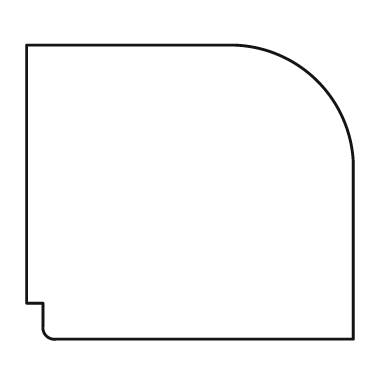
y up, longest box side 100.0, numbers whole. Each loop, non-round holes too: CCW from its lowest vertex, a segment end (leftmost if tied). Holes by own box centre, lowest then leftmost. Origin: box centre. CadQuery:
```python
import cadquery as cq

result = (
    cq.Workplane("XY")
    .moveTo(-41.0, -45.0)
    .lineTo(50.0, -45.0)
    .lineTo(50.0, 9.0)
    .threePointArc((39.0, 34.0), (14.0, 45.0))
    .lineTo(-50.0, 45.0)
    .lineTo(-50.0, -34.0)
    .lineTo(-45.0, -34.0)
    .lineTo(-45.0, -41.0)
    .threePointArc((-44.0, -44.0), (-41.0, -45.0))
    .close()
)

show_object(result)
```